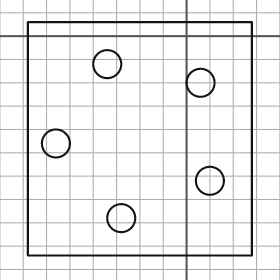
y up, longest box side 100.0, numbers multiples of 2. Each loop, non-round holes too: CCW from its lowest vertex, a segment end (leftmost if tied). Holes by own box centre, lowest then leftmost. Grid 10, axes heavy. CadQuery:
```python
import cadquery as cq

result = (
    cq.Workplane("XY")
    .moveTo(-68.0, -94.0)
    .lineTo(28.0, -94.0)
    .lineTo(28.0, 6.0)
    .lineTo(-68.0, 6.0)
    .close()
    .moveTo(-28.0, -78.0)
    .circle(6.0)
    .moveTo(10.0, -62.0)
    .circle(6.0)
    .moveTo(-56.0, -46.0)
    .circle(6.0)
    .moveTo(6.0, -20.0)
    .circle(6.0)
    .moveTo(-34.0, -12.0)
    .circle(6.0)
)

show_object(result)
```